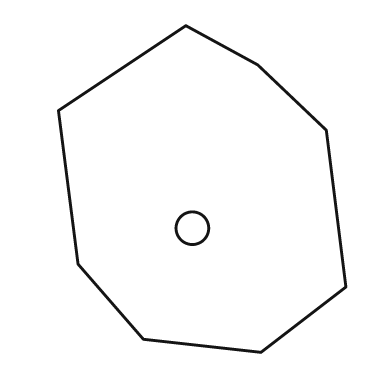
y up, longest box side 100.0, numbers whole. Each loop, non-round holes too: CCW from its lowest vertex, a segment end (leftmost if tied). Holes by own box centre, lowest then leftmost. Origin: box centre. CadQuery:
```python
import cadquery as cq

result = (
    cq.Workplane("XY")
    .moveTo(18.0, -50.0)
    .lineTo(44.0, -30.0)
    .lineTo(38.0, 18.0)
    .lineTo(17.0, 38.0)
    .lineTo(-5.0, 50.0)
    .lineTo(-44.0, 24.0)
    .lineTo(-38.0, -23.0)
    .lineTo(-18.0, -46.0)
    .close()
    .moveTo(-3.0, -12.0)
    .circle(5.0)
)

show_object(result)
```